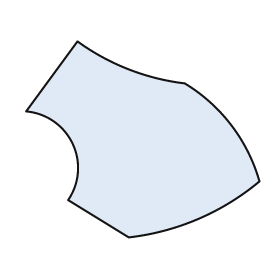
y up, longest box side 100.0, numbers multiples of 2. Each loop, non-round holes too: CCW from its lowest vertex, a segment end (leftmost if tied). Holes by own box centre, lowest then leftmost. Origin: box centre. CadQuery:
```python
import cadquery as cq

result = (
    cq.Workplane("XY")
    .moveTo(-6.0, -42.0)
    .threePointArc((24.0, -34.0), (50.0, -18.0))
    .threePointArc((38.0, 6.0), (18.0, 24.0))
    .threePointArc((-6.0, 30.0), (-28.0, 42.0))
    .lineTo(-50.0, 12.0)
    .threePointArc((-30.0, -2.0), (-32.0, -26.0))
    .close()
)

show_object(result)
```